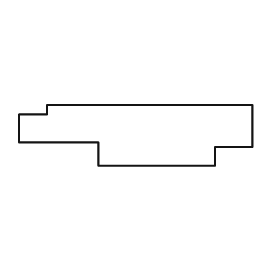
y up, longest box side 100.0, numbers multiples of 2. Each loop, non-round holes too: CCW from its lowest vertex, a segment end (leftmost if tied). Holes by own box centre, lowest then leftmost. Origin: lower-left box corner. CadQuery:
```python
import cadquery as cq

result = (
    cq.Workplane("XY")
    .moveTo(34.0, 0.0)
    .lineTo(84.0, 0.0)
    .lineTo(84.0, 8.0)
    .lineTo(100.0, 8.0)
    .lineTo(100.0, 26.0)
    .lineTo(12.0, 26.0)
    .lineTo(12.0, 22.0)
    .lineTo(0.0, 22.0)
    .lineTo(0.0, 10.0)
    .lineTo(34.0, 10.0)
    .close()
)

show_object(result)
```